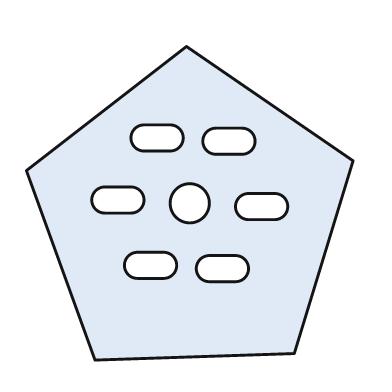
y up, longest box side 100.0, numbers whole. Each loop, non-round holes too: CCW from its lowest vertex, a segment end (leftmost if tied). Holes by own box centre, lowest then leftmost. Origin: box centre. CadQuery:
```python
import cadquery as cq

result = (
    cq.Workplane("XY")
    .moveTo(-29.0, -48.0)
    .lineTo(32.0, -46.0)
    .lineTo(50.0, 13.0)
    .lineTo(-1.0, 48.0)
    .lineTo(-50.0, 10.0)
    .close()
    .moveTo(6.0, -24.0)
    .lineTo(14.0, -24.0)
    .threePointArc((18.0, -20.0), (14.0, -16.0))
    .lineTo(6.0, -16.0)
    .threePointArc((2.0, -20.0), (6.0, -24.0))
    .close()
    .moveTo(-16.0, -23.0)
    .lineTo(-8.0, -23.0)
    .threePointArc((-4.0, -19.0), (-8.0, -15.0))
    .lineTo(-16.0, -15.0)
    .threePointArc((-20.0, -19.0), (-16.0, -23.0))
    .close()
    .moveTo(18.0, -5.0)
    .lineTo(26.0, -5.0)
    .threePointArc((30.0, -1.0), (26.0, 3.0))
    .lineTo(18.0, 3.0)
    .threePointArc((14.0, -1.0), (18.0, -5.0))
    .close()
    .moveTo(0.0, 0.0)
    .circle(6.0)
    .moveTo(-26.0, -3.0)
    .lineTo(-18.0, -3.0)
    .threePointArc((-14.0, 1.0), (-18.0, 5.0))
    .lineTo(-26.0, 5.0)
    .threePointArc((-30.0, 1.0), (-26.0, -3.0))
    .close()
    .moveTo(8.0, 15.0)
    .lineTo(16.0, 15.0)
    .threePointArc((20.0, 19.0), (16.0, 23.0))
    .lineTo(8.0, 23.0)
    .threePointArc((4.0, 19.0), (8.0, 15.0))
    .close()
    .moveTo(-14.0, 16.0)
    .lineTo(-6.0, 16.0)
    .threePointArc((-2.0, 20.0), (-6.0, 24.0))
    .lineTo(-14.0, 24.0)
    .threePointArc((-18.0, 20.0), (-14.0, 16.0))
    .close()
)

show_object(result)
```